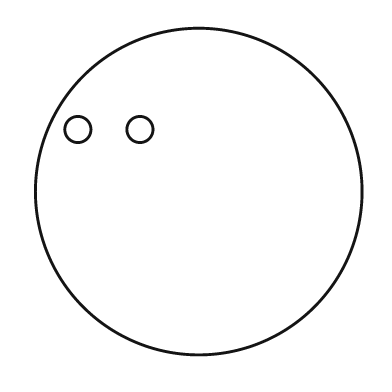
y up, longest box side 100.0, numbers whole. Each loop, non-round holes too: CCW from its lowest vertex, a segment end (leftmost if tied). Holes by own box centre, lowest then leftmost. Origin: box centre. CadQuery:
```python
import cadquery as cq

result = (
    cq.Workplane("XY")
    .moveTo(0.0, 0.0)
    .circle(50.0)
    .moveTo(-37.0, 19.0)
    .circle(4.0)
    .moveTo(-18.0, 19.0)
    .circle(4.0)
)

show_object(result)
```